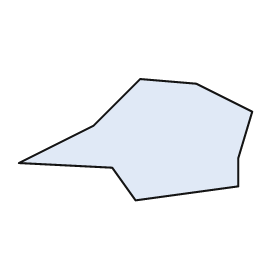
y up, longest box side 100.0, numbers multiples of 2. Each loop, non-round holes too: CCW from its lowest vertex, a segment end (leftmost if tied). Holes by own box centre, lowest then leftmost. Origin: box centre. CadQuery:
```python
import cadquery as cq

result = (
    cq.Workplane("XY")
    .moveTo(0.0, -26.0)
    .lineTo(44.0, -20.0)
    .lineTo(44.0, -8.0)
    .lineTo(50.0, 12.0)
    .lineTo(26.0, 24.0)
    .lineTo(2.0, 26.0)
    .lineTo(-18.0, 6.0)
    .lineTo(-50.0, -10.0)
    .lineTo(-10.0, -12.0)
    .close()
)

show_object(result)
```